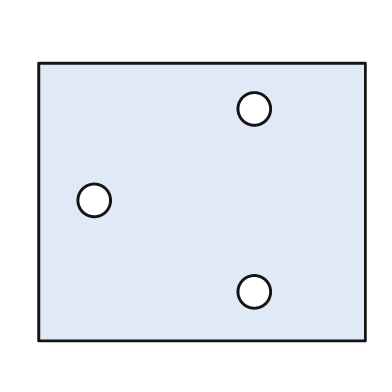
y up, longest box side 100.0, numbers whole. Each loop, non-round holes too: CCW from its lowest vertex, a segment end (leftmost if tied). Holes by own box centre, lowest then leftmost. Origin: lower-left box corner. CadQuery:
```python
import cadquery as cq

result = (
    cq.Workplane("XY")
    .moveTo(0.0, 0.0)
    .lineTo(100.0, 0.0)
    .lineTo(100.0, 85.0)
    .lineTo(0.0, 85.0)
    .close()
    .moveTo(66.0, 15.0)
    .circle(5.0)
    .moveTo(17.0, 43.0)
    .circle(5.0)
    .moveTo(66.0, 71.0)
    .circle(5.0)
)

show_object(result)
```